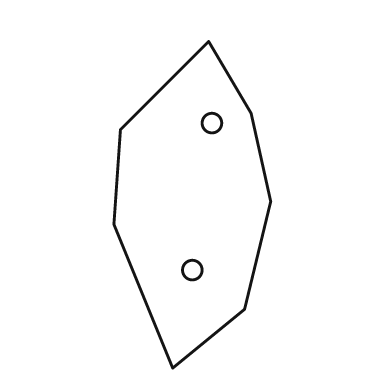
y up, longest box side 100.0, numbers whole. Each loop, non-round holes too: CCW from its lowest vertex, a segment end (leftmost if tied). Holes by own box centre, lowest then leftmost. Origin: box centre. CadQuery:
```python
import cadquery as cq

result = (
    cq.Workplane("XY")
    .moveTo(-6.0, -50.0)
    .lineTo(16.0, -32.0)
    .lineTo(24.0, 1.0)
    .lineTo(18.0, 28.0)
    .lineTo(5.0, 50.0)
    .lineTo(-22.0, 23.0)
    .lineTo(-24.0, -6.0)
    .close()
    .moveTo(0.0, -20.0)
    .circle(3.0)
    .moveTo(6.0, 25.0)
    .circle(3.0)
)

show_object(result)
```